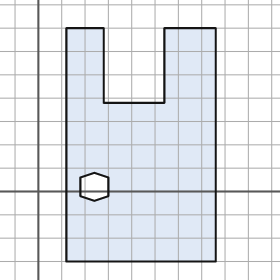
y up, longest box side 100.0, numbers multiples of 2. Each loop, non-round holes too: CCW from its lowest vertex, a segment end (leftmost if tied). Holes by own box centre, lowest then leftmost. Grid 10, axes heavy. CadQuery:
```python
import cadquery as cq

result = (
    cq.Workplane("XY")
    .moveTo(12.0, -30.0)
    .lineTo(76.0, -30.0)
    .lineTo(76.0, 70.0)
    .lineTo(54.0, 70.0)
    .lineTo(54.0, 38.0)
    .lineTo(28.0, 38.0)
    .lineTo(28.0, 70.0)
    .lineTo(12.0, 70.0)
    .close()
    .moveTo(24.0, -4.0)
    .lineTo(30.0, -2.0)
    .lineTo(30.0, 6.0)
    .lineTo(24.0, 8.0)
    .lineTo(18.0, 6.0)
    .lineTo(18.0, -2.0)
    .close()
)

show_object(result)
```